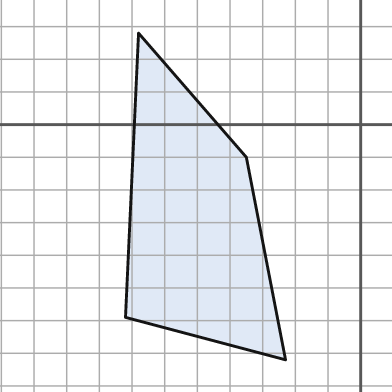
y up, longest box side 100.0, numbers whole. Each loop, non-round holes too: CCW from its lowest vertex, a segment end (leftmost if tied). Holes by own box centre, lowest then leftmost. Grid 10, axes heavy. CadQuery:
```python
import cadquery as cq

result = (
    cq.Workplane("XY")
    .moveTo(-23.0, -72.0)
    .lineTo(-35.0, -10.0)
    .lineTo(-68.0, 28.0)
    .lineTo(-72.0, -59.0)
    .close()
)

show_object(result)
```